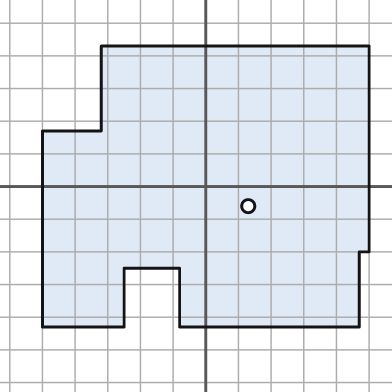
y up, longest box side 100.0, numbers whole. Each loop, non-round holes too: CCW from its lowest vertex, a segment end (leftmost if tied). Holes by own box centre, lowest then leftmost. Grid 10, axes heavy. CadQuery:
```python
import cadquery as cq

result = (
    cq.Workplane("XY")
    .moveTo(-50.0, -43.0)
    .lineTo(-25.0, -43.0)
    .lineTo(-25.0, -25.0)
    .lineTo(-8.0, -25.0)
    .lineTo(-8.0, -43.0)
    .lineTo(47.0, -43.0)
    .lineTo(47.0, -20.0)
    .lineTo(50.0, -20.0)
    .lineTo(50.0, 43.0)
    .lineTo(-32.0, 43.0)
    .lineTo(-32.0, 17.0)
    .lineTo(-50.0, 17.0)
    .close()
    .moveTo(13.0, -6.0)
    .circle(2.0)
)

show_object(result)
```